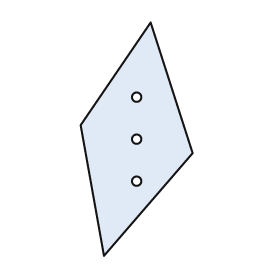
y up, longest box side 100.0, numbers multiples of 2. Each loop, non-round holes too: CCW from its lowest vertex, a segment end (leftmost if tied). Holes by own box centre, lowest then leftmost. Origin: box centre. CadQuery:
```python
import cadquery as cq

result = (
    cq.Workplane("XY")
    .moveTo(-14.0, -50.0)
    .lineTo(24.0, -6.0)
    .lineTo(6.0, 50.0)
    .lineTo(-24.0, 6.0)
    .close()
    .moveTo(0.0, -18.0)
    .circle(2.0)
    .moveTo(0.0, 0.0)
    .circle(2.0)
    .moveTo(0.0, 18.0)
    .circle(2.0)
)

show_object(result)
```